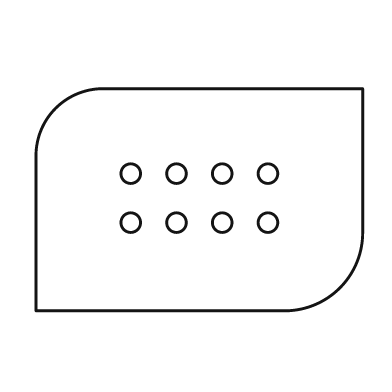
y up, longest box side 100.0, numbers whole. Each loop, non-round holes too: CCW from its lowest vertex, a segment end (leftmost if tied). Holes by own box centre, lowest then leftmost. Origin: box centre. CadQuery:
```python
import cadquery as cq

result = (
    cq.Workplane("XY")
    .moveTo(-50.0, -34.0)
    .lineTo(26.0, -34.0)
    .threePointArc((43.0, -27.0), (50.0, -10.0))
    .lineTo(50.0, 34.0)
    .lineTo(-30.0, 34.0)
    .threePointArc((-44.0, 28.0), (-50.0, 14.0))
    .close()
    .moveTo(-21.0, -7.0)
    .circle(3.0)
    .moveTo(-7.0, -7.0)
    .circle(3.0)
    .moveTo(7.0, -7.0)
    .circle(3.0)
    .moveTo(21.0, -7.0)
    .circle(3.0)
    .moveTo(-21.0, 8.0)
    .circle(3.0)
    .moveTo(-7.0, 8.0)
    .circle(3.0)
    .moveTo(7.0, 8.0)
    .circle(3.0)
    .moveTo(21.0, 8.0)
    .circle(3.0)
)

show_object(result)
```